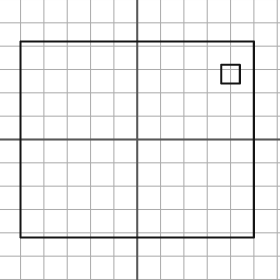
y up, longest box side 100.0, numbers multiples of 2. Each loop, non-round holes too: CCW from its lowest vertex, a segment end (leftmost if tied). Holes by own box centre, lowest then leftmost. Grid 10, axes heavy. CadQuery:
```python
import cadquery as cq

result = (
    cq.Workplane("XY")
    .moveTo(-50.0, -42.0)
    .lineTo(50.0, -42.0)
    .lineTo(50.0, 42.0)
    .lineTo(-50.0, 42.0)
    .close()
    .moveTo(36.0, 24.0)
    .lineTo(44.0, 24.0)
    .lineTo(44.0, 32.0)
    .lineTo(36.0, 32.0)
    .close()
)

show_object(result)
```